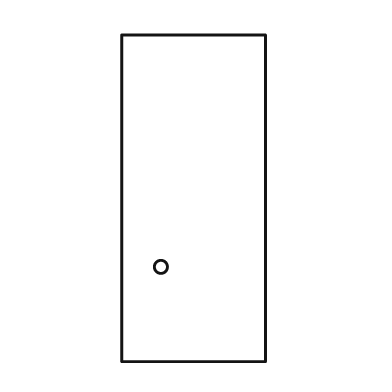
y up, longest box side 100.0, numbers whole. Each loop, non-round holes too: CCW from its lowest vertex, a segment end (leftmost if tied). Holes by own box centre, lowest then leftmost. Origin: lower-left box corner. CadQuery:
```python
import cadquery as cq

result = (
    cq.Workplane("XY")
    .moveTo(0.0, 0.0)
    .lineTo(44.0, 0.0)
    .lineTo(44.0, 100.0)
    .lineTo(0.0, 100.0)
    .close()
    .moveTo(12.0, 29.0)
    .circle(2.0)
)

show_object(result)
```